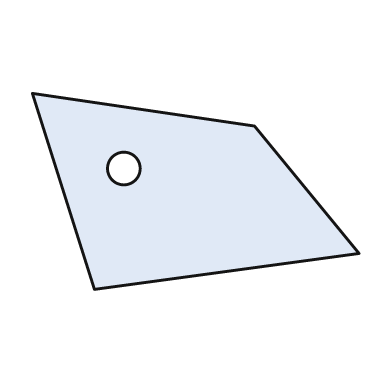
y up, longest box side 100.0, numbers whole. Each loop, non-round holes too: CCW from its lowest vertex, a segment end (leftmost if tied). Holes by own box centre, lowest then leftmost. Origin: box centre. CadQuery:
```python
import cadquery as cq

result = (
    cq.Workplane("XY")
    .moveTo(-31.0, -30.0)
    .lineTo(50.0, -19.0)
    .lineTo(18.0, 20.0)
    .lineTo(-50.0, 30.0)
    .close()
    .moveTo(-22.0, 7.0)
    .circle(5.0)
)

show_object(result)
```